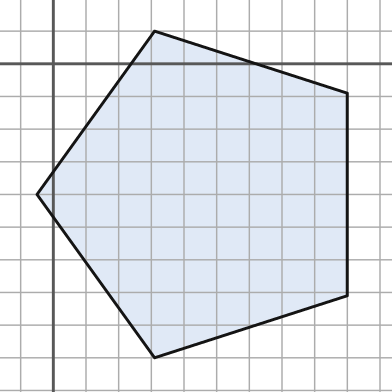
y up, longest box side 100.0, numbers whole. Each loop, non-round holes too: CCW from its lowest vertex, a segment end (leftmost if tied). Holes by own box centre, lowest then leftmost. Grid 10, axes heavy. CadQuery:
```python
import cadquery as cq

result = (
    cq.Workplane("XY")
    .moveTo(31.0, -90.0)
    .lineTo(90.0, -71.0)
    .lineTo(90.0, -9.0)
    .lineTo(31.0, 10.0)
    .lineTo(-5.0, -40.0)
    .close()
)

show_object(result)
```